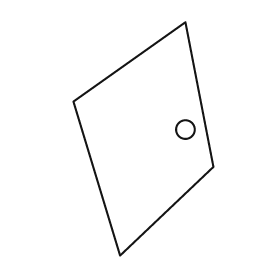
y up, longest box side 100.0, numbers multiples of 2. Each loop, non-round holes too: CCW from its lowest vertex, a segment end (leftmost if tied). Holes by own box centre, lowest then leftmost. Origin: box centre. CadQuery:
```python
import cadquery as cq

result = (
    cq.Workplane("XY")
    .moveTo(-10.0, -50.0)
    .lineTo(30.0, -12.0)
    .lineTo(18.0, 50.0)
    .lineTo(-30.0, 16.0)
    .close()
    .moveTo(18.0, 4.0)
    .circle(4.0)
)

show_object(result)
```